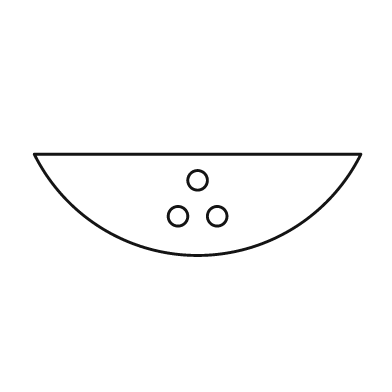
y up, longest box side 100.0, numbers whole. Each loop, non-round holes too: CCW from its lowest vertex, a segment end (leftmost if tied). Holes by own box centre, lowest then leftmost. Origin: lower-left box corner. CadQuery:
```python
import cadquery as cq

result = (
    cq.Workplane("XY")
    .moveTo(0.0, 31.0)
    .threePointArc((50.0, 0.0), (100.0, 31.0))
    .close()
    .moveTo(44.0, 12.0)
    .circle(3.0)
    .moveTo(56.0, 12.0)
    .circle(3.0)
    .moveTo(50.0, 23.0)
    .circle(3.0)
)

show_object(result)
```